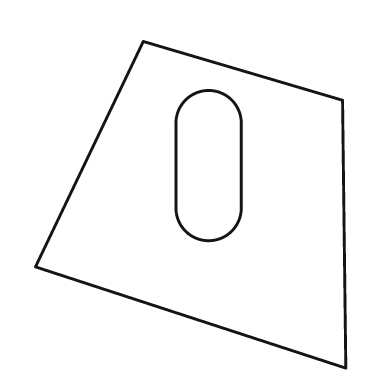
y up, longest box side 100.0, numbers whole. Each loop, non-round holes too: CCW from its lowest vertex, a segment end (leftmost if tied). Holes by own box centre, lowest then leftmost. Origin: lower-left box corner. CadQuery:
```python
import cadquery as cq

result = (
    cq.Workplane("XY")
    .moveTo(95.0, 0.0)
    .lineTo(94.0, 82.0)
    .lineTo(33.0, 100.0)
    .lineTo(0.0, 31.0)
    .close()
    .moveTo(43.0, 49.0)
    .threePointArc((53.0, 39.0), (63.0, 49.0))
    .lineTo(63.0, 75.0)
    .threePointArc((53.0, 85.0), (43.0, 75.0))
    .close()
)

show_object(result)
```